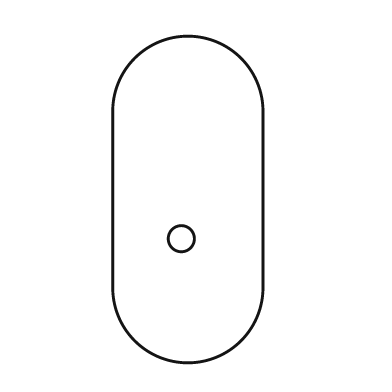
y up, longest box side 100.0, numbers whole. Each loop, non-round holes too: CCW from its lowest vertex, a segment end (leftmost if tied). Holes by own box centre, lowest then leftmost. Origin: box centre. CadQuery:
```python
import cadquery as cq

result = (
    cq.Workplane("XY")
    .moveTo(-23.0, -27.0)
    .threePointArc((0.0, -50.0), (23.0, -27.0))
    .lineTo(23.0, 27.0)
    .threePointArc((0.0, 50.0), (-23.0, 27.0))
    .close()
    .moveTo(-2.0, -12.0)
    .circle(4.0)
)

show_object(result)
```